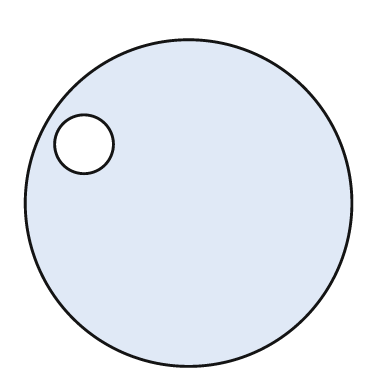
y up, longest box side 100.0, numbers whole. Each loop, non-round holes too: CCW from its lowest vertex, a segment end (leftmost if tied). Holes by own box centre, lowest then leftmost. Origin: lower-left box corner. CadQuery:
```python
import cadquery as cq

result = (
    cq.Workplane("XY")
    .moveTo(50.0, 50.0)
    .circle(50.0)
    .moveTo(18.0, 68.0)
    .circle(9.0)
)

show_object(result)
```